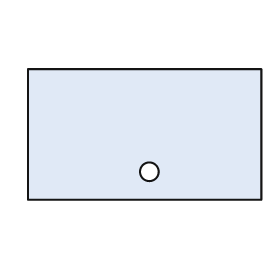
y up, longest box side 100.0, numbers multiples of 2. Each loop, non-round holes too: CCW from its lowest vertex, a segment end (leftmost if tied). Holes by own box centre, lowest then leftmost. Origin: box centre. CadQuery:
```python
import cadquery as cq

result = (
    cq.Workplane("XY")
    .moveTo(-50.0, -28.0)
    .lineTo(50.0, -28.0)
    .lineTo(50.0, 28.0)
    .lineTo(-50.0, 28.0)
    .close()
    .moveTo(2.0, -16.0)
    .circle(4.0)
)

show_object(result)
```